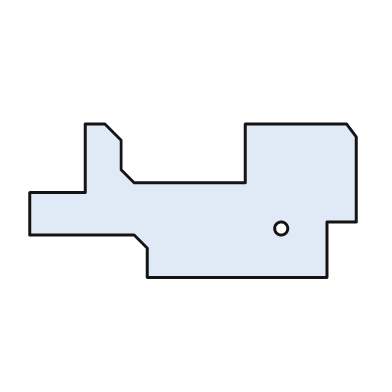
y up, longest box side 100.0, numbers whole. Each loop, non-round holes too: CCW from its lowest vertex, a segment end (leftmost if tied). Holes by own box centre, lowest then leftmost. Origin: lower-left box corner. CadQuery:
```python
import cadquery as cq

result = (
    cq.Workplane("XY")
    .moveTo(36.0, 0.0)
    .lineTo(91.0, 0.0)
    .lineTo(91.0, 17.0)
    .lineTo(100.0, 17.0)
    .lineTo(100.0, 43.0)
    .lineTo(97.0, 47.0)
    .lineTo(66.0, 47.0)
    .lineTo(66.0, 29.0)
    .lineTo(32.0, 29.0)
    .lineTo(28.0, 33.0)
    .lineTo(28.0, 42.0)
    .lineTo(23.0, 47.0)
    .lineTo(17.0, 47.0)
    .lineTo(17.0, 26.0)
    .lineTo(0.0, 26.0)
    .lineTo(0.0, 13.0)
    .lineTo(32.0, 13.0)
    .lineTo(36.0, 9.0)
    .close()
    .moveTo(77.0, 15.0)
    .circle(2.0)
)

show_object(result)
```